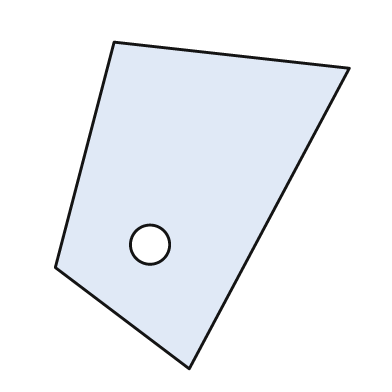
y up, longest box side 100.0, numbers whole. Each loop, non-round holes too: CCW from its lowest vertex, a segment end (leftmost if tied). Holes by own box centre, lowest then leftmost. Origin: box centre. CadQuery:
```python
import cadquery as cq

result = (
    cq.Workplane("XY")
    .moveTo(-4.0, -50.0)
    .lineTo(45.0, 42.0)
    .lineTo(-27.0, 50.0)
    .lineTo(-45.0, -19.0)
    .close()
    .moveTo(-16.0, -12.0)
    .circle(6.0)
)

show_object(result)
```